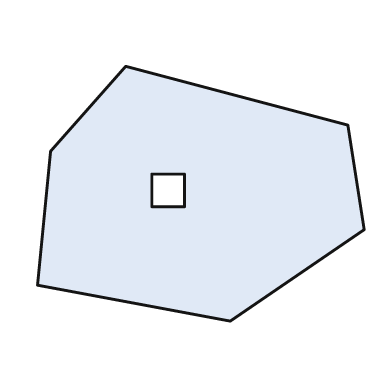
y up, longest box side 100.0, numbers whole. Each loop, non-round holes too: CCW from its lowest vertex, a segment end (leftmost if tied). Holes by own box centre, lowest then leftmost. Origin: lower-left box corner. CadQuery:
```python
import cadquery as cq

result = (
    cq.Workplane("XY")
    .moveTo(59.0, 0.0)
    .lineTo(100.0, 28.0)
    .lineTo(95.0, 60.0)
    .lineTo(27.0, 78.0)
    .lineTo(4.0, 52.0)
    .lineTo(0.0, 11.0)
    .close()
    .moveTo(35.0, 35.0)
    .lineTo(45.0, 35.0)
    .lineTo(45.0, 45.0)
    .lineTo(35.0, 45.0)
    .close()
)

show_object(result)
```